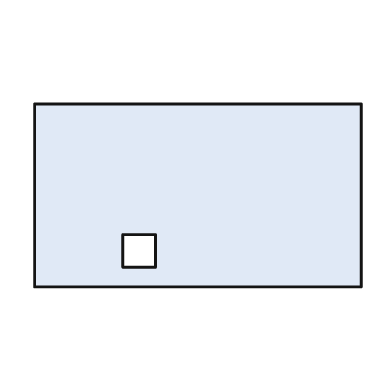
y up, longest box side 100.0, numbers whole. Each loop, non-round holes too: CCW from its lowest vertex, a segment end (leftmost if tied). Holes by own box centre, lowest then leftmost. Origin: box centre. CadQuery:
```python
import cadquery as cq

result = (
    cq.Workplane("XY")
    .moveTo(-50.0, -28.0)
    .lineTo(50.0, -28.0)
    .lineTo(50.0, 28.0)
    .lineTo(-50.0, 28.0)
    .close()
    .moveTo(-23.0, -22.0)
    .lineTo(-13.0, -22.0)
    .lineTo(-13.0, -12.0)
    .lineTo(-23.0, -12.0)
    .close()
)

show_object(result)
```